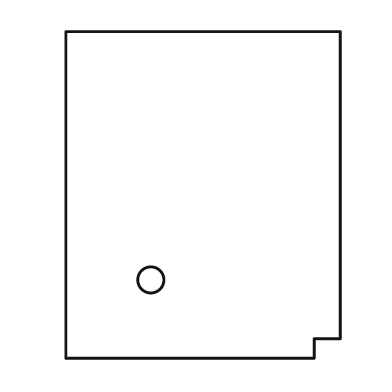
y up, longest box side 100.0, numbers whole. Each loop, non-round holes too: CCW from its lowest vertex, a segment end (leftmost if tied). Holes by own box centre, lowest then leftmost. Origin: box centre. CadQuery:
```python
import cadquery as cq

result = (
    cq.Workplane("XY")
    .moveTo(-42.0, -50.0)
    .lineTo(34.0, -50.0)
    .lineTo(34.0, -44.0)
    .lineTo(42.0, -44.0)
    .lineTo(42.0, 50.0)
    .lineTo(-42.0, 50.0)
    .close()
    .moveTo(-16.0, -26.0)
    .circle(4.0)
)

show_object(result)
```